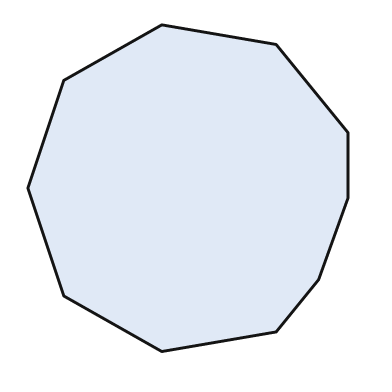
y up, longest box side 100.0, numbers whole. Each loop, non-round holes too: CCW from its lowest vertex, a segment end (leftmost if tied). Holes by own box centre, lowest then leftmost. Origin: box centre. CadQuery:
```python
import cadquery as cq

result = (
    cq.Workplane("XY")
    .moveTo(-8.0, -50.0)
    .lineTo(27.0, -44.0)
    .lineTo(40.0, -28.0)
    .lineTo(49.0, -3.0)
    .lineTo(49.0, 17.0)
    .lineTo(27.0, 44.0)
    .lineTo(-8.0, 50.0)
    .lineTo(-38.0, 33.0)
    .lineTo(-49.0, 0.0)
    .lineTo(-38.0, -33.0)
    .close()
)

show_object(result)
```